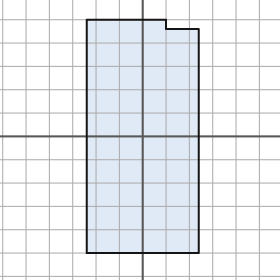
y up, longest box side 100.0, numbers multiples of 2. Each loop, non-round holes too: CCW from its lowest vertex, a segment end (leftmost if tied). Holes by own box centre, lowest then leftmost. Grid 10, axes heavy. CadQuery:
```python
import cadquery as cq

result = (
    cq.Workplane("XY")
    .moveTo(-24.0, -50.0)
    .lineTo(24.0, -50.0)
    .lineTo(24.0, 46.0)
    .lineTo(10.0, 46.0)
    .lineTo(10.0, 50.0)
    .lineTo(-24.0, 50.0)
    .close()
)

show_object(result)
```